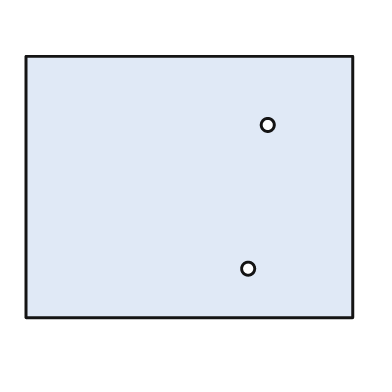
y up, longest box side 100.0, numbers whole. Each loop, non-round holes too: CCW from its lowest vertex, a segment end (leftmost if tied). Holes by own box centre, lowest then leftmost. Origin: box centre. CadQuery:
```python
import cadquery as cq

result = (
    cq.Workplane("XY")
    .moveTo(-50.0, -40.0)
    .lineTo(50.0, -40.0)
    .lineTo(50.0, 40.0)
    .lineTo(-50.0, 40.0)
    .close()
    .moveTo(18.0, -25.0)
    .circle(2.0)
    .moveTo(24.0, 19.0)
    .circle(2.0)
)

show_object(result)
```